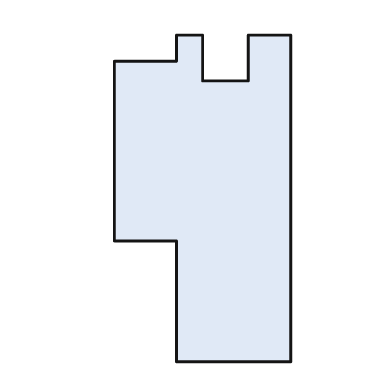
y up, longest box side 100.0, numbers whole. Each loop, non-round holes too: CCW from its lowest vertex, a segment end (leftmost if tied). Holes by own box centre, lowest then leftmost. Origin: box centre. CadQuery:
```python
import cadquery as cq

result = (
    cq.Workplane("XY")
    .moveTo(-8.0, -50.0)
    .lineTo(27.0, -50.0)
    .lineTo(27.0, 50.0)
    .lineTo(14.0, 50.0)
    .lineTo(14.0, 36.0)
    .lineTo(0.0, 36.0)
    .lineTo(0.0, 50.0)
    .lineTo(-8.0, 50.0)
    .lineTo(-8.0, 42.0)
    .lineTo(-27.0, 42.0)
    .lineTo(-27.0, -13.0)
    .lineTo(-8.0, -13.0)
    .close()
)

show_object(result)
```